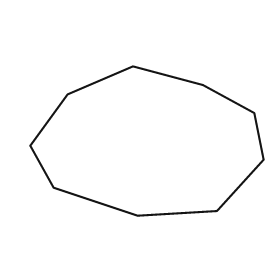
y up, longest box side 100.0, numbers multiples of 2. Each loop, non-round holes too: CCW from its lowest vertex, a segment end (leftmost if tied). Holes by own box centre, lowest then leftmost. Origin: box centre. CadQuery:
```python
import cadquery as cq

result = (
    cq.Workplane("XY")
    .moveTo(-4.0, -32.0)
    .lineTo(30.0, -30.0)
    .lineTo(50.0, -8.0)
    .lineTo(46.0, 12.0)
    .lineTo(24.0, 24.0)
    .lineTo(-6.0, 32.0)
    .lineTo(-34.0, 20.0)
    .lineTo(-50.0, -2.0)
    .lineTo(-40.0, -20.0)
    .close()
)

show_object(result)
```